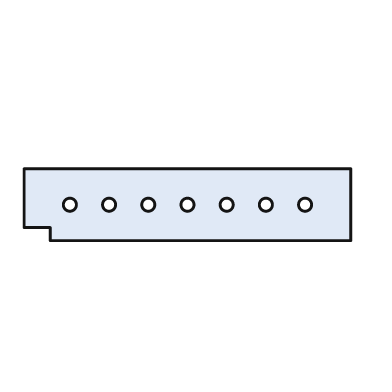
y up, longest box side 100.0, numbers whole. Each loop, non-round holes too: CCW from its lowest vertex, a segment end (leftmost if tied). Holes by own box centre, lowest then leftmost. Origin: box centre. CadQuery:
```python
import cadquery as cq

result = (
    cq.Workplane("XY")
    .moveTo(-42.0, -11.0)
    .lineTo(50.0, -11.0)
    .lineTo(50.0, 11.0)
    .lineTo(-50.0, 11.0)
    .lineTo(-50.0, -7.0)
    .lineTo(-42.0, -7.0)
    .close()
    .moveTo(-36.0, 0.0)
    .circle(2.0)
    .moveTo(-24.0, 0.0)
    .circle(2.0)
    .moveTo(-12.0, 0.0)
    .circle(2.0)
    .moveTo(0.0, 0.0)
    .circle(2.0)
    .moveTo(12.0, 0.0)
    .circle(2.0)
    .moveTo(24.0, 0.0)
    .circle(2.0)
    .moveTo(36.0, 0.0)
    .circle(2.0)
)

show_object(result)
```